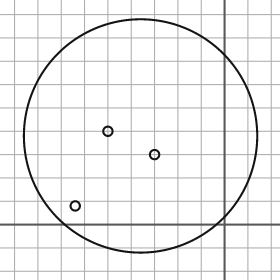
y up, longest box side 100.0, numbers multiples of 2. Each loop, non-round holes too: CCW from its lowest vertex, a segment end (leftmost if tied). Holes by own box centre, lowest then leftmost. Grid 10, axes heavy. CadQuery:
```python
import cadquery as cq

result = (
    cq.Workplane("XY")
    .moveTo(-36.0, 38.0)
    .circle(50.0)
    .moveTo(-64.0, 8.0)
    .circle(2.0)
    .moveTo(-30.0, 30.0)
    .circle(2.0)
    .moveTo(-50.0, 40.0)
    .circle(2.0)
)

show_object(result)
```